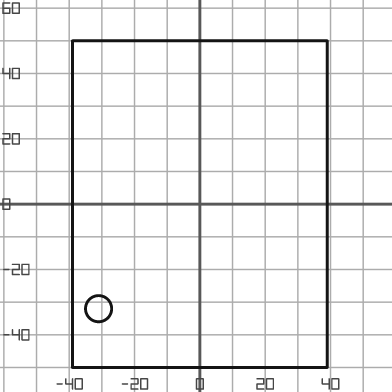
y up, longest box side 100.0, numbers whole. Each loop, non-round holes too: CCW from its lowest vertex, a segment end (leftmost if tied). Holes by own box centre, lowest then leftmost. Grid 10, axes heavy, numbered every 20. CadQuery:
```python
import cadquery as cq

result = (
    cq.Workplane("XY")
    .moveTo(-39.0, -50.0)
    .lineTo(39.0, -50.0)
    .lineTo(39.0, 50.0)
    .lineTo(-39.0, 50.0)
    .close()
    .moveTo(-31.0, -32.0)
    .circle(4.0)
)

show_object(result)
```